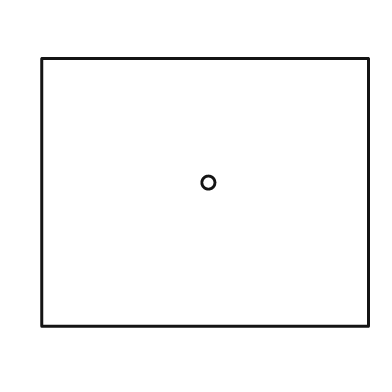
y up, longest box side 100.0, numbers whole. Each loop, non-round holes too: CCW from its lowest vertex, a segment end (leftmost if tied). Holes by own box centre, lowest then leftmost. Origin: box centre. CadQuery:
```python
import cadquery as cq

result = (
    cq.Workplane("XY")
    .moveTo(-50.0, -41.0)
    .lineTo(50.0, -41.0)
    .lineTo(50.0, 41.0)
    .lineTo(-50.0, 41.0)
    .close()
    .moveTo(1.0, 3.0)
    .circle(2.0)
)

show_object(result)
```